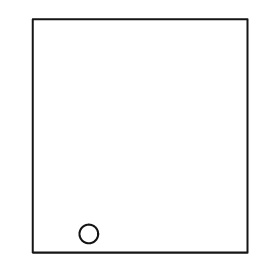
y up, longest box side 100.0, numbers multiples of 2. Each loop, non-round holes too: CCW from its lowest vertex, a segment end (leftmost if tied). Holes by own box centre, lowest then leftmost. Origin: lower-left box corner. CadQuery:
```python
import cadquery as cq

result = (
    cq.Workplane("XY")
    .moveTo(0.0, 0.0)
    .lineTo(92.0, 0.0)
    .lineTo(92.0, 100.0)
    .lineTo(0.0, 100.0)
    .close()
    .moveTo(24.0, 8.0)
    .circle(4.0)
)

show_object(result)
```